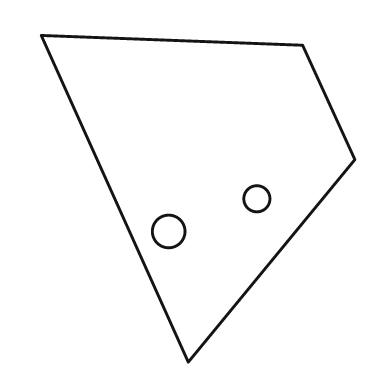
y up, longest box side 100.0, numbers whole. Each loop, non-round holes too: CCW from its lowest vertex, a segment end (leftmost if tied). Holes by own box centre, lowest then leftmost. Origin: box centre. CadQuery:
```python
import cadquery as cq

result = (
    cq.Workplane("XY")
    .moveTo(-3.0, -50.0)
    .lineTo(48.0, 12.0)
    .lineTo(32.0, 47.0)
    .lineTo(-48.0, 50.0)
    .close()
    .moveTo(-9.0, -10.0)
    .circle(5.0)
    .moveTo(18.0, 0.0)
    .circle(4.0)
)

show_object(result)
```